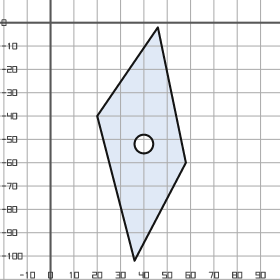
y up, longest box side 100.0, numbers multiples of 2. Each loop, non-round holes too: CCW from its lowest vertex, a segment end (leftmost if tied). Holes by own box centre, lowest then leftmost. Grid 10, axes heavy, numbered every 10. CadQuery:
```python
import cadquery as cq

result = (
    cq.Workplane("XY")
    .moveTo(36.0, -102.0)
    .lineTo(58.0, -60.0)
    .lineTo(46.0, -2.0)
    .lineTo(20.0, -40.0)
    .close()
    .moveTo(40.0, -52.0)
    .circle(4.0)
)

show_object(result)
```